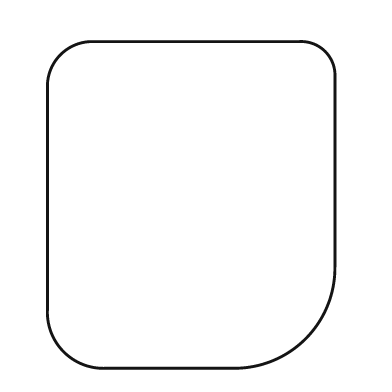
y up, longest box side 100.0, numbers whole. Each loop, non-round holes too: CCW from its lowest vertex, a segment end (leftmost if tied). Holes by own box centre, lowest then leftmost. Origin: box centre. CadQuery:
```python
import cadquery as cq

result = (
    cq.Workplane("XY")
    .moveTo(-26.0, -50.0)
    .lineTo(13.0, -50.0)
    .threePointArc((35.0, -41.0), (44.0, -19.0))
    .lineTo(44.0, 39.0)
    .threePointArc((41.0, 47.0), (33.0, 50.0))
    .lineTo(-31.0, 50.0)
    .threePointArc((-40.0, 46.0), (-44.0, 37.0))
    .lineTo(-44.0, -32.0)
    .threePointArc((-39.0, -45.0), (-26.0, -50.0))
    .close()
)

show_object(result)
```